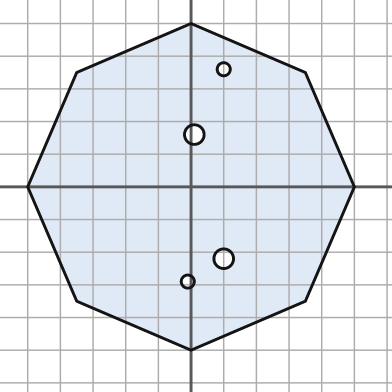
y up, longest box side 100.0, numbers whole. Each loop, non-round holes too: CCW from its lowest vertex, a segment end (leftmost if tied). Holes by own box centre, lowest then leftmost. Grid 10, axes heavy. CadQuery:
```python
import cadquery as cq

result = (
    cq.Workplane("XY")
    .moveTo(0.0, -50.0)
    .lineTo(35.0, -35.0)
    .lineTo(50.0, 0.0)
    .lineTo(35.0, 35.0)
    .lineTo(0.0, 50.0)
    .lineTo(-35.0, 35.0)
    .lineTo(-50.0, 0.0)
    .lineTo(-35.0, -35.0)
    .close()
    .moveTo(-1.0, -29.0)
    .circle(2.0)
    .moveTo(10.0, -22.0)
    .circle(3.0)
    .moveTo(1.0, 16.0)
    .circle(3.0)
    .moveTo(10.0, 36.0)
    .circle(2.0)
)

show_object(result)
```